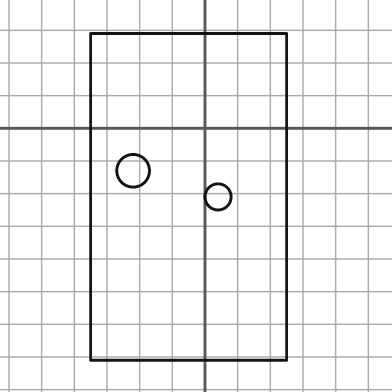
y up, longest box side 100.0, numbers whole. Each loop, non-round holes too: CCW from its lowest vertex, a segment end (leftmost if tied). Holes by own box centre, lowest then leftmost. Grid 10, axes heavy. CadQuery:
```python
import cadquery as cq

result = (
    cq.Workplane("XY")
    .moveTo(-35.0, -71.0)
    .lineTo(25.0, -71.0)
    .lineTo(25.0, 29.0)
    .lineTo(-35.0, 29.0)
    .close()
    .moveTo(4.0, -21.0)
    .circle(4.0)
    .moveTo(-22.0, -13.0)
    .circle(5.0)
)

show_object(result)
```